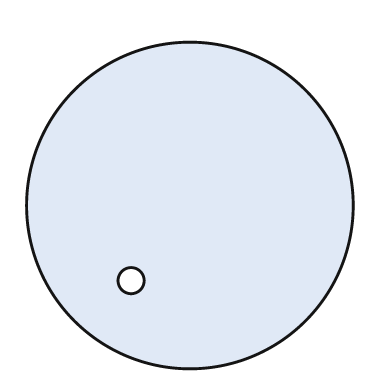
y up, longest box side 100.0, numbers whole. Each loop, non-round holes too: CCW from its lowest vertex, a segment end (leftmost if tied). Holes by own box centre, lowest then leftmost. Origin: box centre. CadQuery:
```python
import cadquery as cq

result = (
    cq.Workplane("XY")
    .moveTo(0.0, 0.0)
    .circle(50.0)
    .moveTo(-18.0, -23.0)
    .circle(4.0)
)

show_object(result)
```